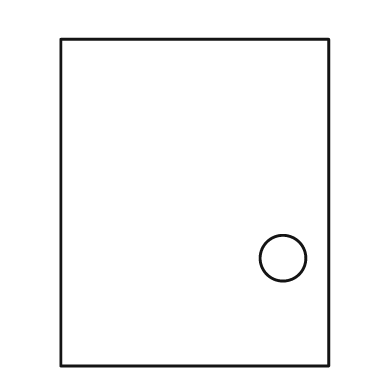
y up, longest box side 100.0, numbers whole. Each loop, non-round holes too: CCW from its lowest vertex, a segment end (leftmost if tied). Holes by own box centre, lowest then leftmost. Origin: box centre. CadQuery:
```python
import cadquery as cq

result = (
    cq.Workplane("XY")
    .moveTo(-41.0, -50.0)
    .lineTo(41.0, -50.0)
    .lineTo(41.0, 50.0)
    .lineTo(-41.0, 50.0)
    .close()
    .moveTo(27.0, -17.0)
    .circle(7.0)
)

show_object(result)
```